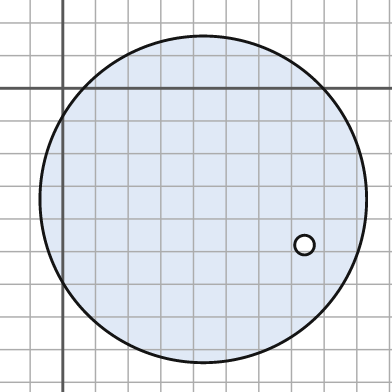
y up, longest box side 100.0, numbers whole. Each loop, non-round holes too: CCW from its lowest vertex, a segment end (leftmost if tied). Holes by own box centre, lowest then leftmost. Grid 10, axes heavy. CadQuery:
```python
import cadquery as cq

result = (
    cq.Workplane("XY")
    .moveTo(43.0, -34.0)
    .circle(50.0)
    .moveTo(74.0, -48.0)
    .circle(3.0)
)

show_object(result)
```